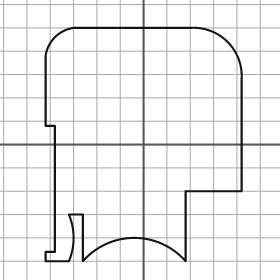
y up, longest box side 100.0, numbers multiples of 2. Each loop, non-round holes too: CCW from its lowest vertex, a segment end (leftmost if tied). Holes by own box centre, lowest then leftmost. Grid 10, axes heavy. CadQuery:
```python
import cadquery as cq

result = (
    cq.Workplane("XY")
    .moveTo(-42.0, -50.0)
    .lineTo(-32.0, -50.0)
    .threePointArc((-30.0, -40.0), (-32.0, -30.0))
    .lineTo(-26.0, -30.0)
    .lineTo(-26.0, -50.0)
    .threePointArc((-4.0, -40.0), (18.0, -50.0))
    .lineTo(18.0, -20.0)
    .lineTo(42.0, -20.0)
    .lineTo(42.0, 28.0)
    .threePointArc((36.0, 44.0), (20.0, 50.0))
    .lineTo(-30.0, 50.0)
    .threePointArc((-38.0, 46.0), (-42.0, 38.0))
    .lineTo(-42.0, 8.0)
    .lineTo(-38.0, 8.0)
    .lineTo(-38.0, -46.0)
    .lineTo(-42.0, -46.0)
    .close()
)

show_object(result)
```